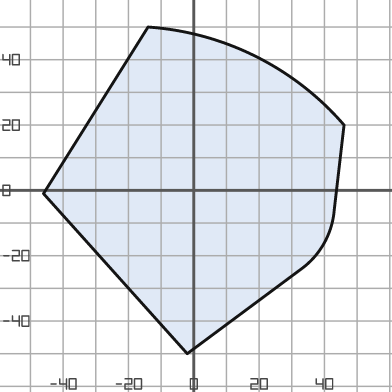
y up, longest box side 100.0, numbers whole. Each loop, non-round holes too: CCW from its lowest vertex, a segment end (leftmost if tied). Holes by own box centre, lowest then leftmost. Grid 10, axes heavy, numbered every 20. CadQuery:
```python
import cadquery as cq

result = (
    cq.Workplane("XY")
    .moveTo(-2.0, -50.0)
    .lineTo(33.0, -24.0)
    .threePointArc((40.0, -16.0), (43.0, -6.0))
    .lineTo(46.0, 20.0)
    .threePointArc((19.0, 41.0), (-14.0, 50.0))
    .lineTo(-46.0, -1.0)
    .close()
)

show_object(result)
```